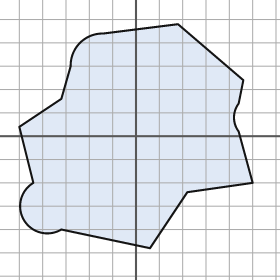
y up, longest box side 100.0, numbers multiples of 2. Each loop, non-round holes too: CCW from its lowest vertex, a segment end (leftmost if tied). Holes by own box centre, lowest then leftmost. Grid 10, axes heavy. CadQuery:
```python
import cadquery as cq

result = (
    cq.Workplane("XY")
    .moveTo(6.0, -48.0)
    .lineTo(22.0, -24.0)
    .lineTo(50.0, -20.0)
    .lineTo(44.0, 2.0)
    .threePointArc((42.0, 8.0), (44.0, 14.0))
    .lineTo(46.0, 24.0)
    .lineTo(18.0, 48.0)
    .lineTo(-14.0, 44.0)
    .threePointArc((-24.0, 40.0), (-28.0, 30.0))
    .lineTo(-32.0, 16.0)
    .lineTo(-50.0, 4.0)
    .lineTo(-44.0, -20.0)
    .threePointArc((-48.0, -36.0), (-32.0, -40.0))
    .close()
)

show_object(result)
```